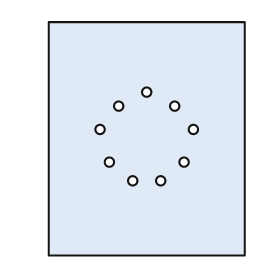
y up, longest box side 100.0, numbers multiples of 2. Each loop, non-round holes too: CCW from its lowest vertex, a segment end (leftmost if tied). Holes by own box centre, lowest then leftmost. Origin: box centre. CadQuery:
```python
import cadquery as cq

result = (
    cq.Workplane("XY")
    .moveTo(-42.0, -50.0)
    .lineTo(42.0, -50.0)
    .lineTo(42.0, 50.0)
    .lineTo(-42.0, 50.0)
    .close()
    .moveTo(-6.0, -18.0)
    .circle(2.0)
    .moveTo(6.0, -18.0)
    .circle(2.0)
    .moveTo(-16.0, -10.0)
    .circle(2.0)
    .moveTo(16.0, -10.0)
    .circle(2.0)
    .moveTo(-20.0, 4.0)
    .circle(2.0)
    .moveTo(20.0, 4.0)
    .circle(2.0)
    .moveTo(-12.0, 14.0)
    .circle(2.0)
    .moveTo(12.0, 14.0)
    .circle(2.0)
    .moveTo(0.0, 20.0)
    .circle(2.0)
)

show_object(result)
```